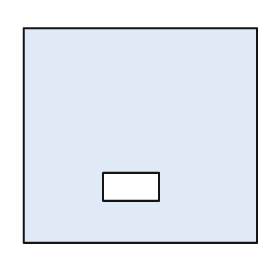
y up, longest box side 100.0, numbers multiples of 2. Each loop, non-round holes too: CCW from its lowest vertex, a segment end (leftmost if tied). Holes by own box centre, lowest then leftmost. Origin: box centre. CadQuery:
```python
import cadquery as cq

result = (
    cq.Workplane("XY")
    .moveTo(-50.0, -46.0)
    .lineTo(50.0, -46.0)
    .lineTo(50.0, 46.0)
    .lineTo(-50.0, 46.0)
    .close()
    .moveTo(-16.0, -28.0)
    .lineTo(8.0, -28.0)
    .lineTo(8.0, -16.0)
    .lineTo(-16.0, -16.0)
    .close()
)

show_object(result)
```